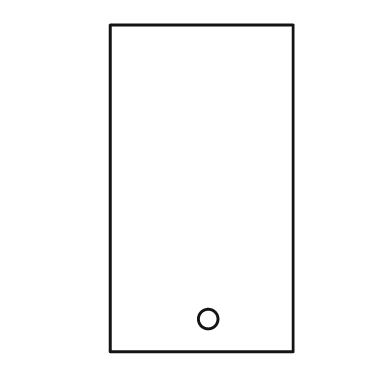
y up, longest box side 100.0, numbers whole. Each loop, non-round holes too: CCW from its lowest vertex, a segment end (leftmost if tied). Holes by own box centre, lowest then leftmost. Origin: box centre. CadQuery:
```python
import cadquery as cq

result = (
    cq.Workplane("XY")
    .moveTo(-28.0, -50.0)
    .lineTo(28.0, -50.0)
    .lineTo(28.0, 50.0)
    .lineTo(-28.0, 50.0)
    .close()
    .moveTo(2.0, -40.0)
    .circle(3.0)
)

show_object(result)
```